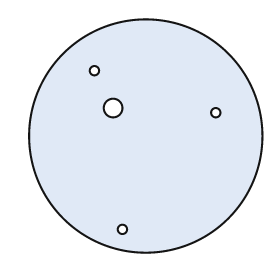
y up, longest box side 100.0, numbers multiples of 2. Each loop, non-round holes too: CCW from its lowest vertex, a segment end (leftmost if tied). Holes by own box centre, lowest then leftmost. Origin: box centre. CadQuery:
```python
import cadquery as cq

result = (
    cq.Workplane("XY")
    .moveTo(0.0, 0.0)
    .circle(50.0)
    .moveTo(-10.0, -40.0)
    .circle(2.0)
    .moveTo(30.0, 10.0)
    .circle(2.0)
    .moveTo(-14.0, 12.0)
    .circle(4.0)
    .moveTo(-22.0, 28.0)
    .circle(2.0)
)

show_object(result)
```